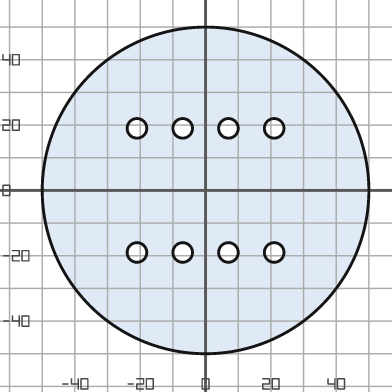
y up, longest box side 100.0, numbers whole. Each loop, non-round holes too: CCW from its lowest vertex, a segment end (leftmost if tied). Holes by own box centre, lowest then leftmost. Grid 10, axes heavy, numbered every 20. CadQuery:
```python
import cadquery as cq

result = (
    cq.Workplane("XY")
    .moveTo(0.0, 0.0)
    .circle(50.0)
    .moveTo(-21.0, -19.0)
    .circle(3.0)
    .moveTo(-7.0, -19.0)
    .circle(3.0)
    .moveTo(7.0, -19.0)
    .circle(3.0)
    .moveTo(21.0, -19.0)
    .circle(3.0)
    .moveTo(-21.0, 19.0)
    .circle(3.0)
    .moveTo(-7.0, 19.0)
    .circle(3.0)
    .moveTo(7.0, 19.0)
    .circle(3.0)
    .moveTo(21.0, 19.0)
    .circle(3.0)
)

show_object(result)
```